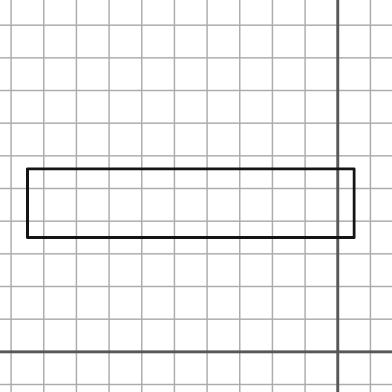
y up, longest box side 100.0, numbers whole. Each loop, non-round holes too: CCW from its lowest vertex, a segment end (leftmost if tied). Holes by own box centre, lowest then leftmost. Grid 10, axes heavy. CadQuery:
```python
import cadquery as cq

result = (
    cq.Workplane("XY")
    .moveTo(-95.0, 35.0)
    .lineTo(5.0, 35.0)
    .lineTo(5.0, 56.0)
    .lineTo(-95.0, 56.0)
    .close()
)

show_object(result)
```